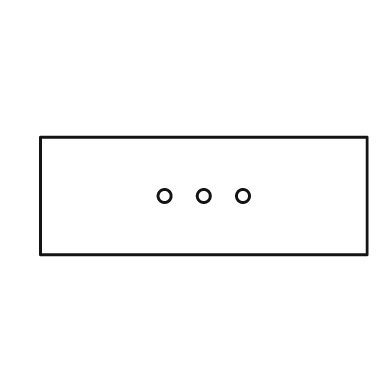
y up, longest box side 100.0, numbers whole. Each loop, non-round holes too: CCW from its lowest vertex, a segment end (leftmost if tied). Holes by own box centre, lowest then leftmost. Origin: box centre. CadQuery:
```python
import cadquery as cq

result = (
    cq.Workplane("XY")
    .moveTo(-50.0, -18.0)
    .lineTo(50.0, -18.0)
    .lineTo(50.0, 18.0)
    .lineTo(-50.0, 18.0)
    .close()
    .moveTo(-12.0, 0.0)
    .circle(2.0)
    .moveTo(0.0, 0.0)
    .circle(2.0)
    .moveTo(12.0, 0.0)
    .circle(2.0)
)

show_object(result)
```